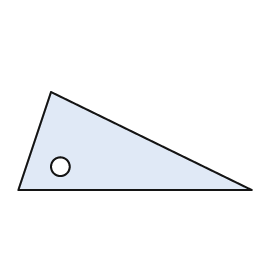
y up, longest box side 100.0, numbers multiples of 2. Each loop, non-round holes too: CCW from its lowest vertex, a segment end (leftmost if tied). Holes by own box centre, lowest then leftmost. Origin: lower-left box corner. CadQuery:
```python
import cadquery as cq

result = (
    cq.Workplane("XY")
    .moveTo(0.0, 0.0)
    .lineTo(100.0, 0.0)
    .lineTo(14.0, 42.0)
    .close()
    .moveTo(18.0, 10.0)
    .circle(4.0)
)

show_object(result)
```